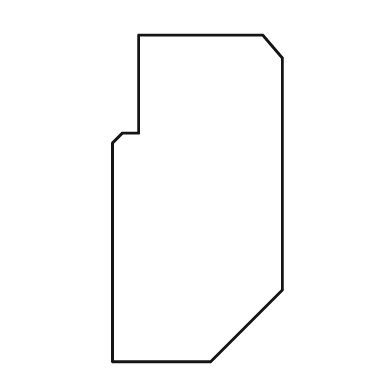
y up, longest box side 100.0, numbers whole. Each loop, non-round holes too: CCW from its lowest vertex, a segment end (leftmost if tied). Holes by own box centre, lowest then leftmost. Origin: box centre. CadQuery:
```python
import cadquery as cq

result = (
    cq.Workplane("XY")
    .moveTo(-26.0, -50.0)
    .lineTo(4.0, -50.0)
    .lineTo(26.0, -28.0)
    .lineTo(26.0, 43.0)
    .lineTo(20.0, 50.0)
    .lineTo(-18.0, 50.0)
    .lineTo(-18.0, 20.0)
    .lineTo(-23.0, 20.0)
    .lineTo(-26.0, 17.0)
    .close()
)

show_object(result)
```